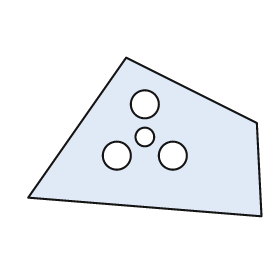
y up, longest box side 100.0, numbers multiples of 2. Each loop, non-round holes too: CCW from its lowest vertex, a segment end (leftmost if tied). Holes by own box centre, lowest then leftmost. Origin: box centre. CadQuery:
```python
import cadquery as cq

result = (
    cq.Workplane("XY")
    .moveTo(50.0, -34.0)
    .lineTo(48.0, 6.0)
    .lineTo(-8.0, 34.0)
    .lineTo(-50.0, -26.0)
    .close()
    .moveTo(-12.0, -8.0)
    .circle(6.0)
    .moveTo(12.0, -8.0)
    .circle(6.0)
    .moveTo(0.0, 0.0)
    .circle(4.0)
    .moveTo(0.0, 14.0)
    .circle(6.0)
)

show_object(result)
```